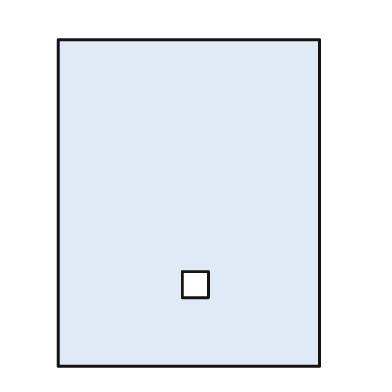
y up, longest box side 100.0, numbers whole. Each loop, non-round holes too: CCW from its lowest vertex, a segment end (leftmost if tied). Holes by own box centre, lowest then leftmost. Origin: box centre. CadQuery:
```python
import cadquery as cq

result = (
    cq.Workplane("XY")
    .moveTo(-40.0, -50.0)
    .lineTo(40.0, -50.0)
    .lineTo(40.0, 50.0)
    .lineTo(-40.0, 50.0)
    .close()
    .moveTo(-2.0, -29.0)
    .lineTo(6.0, -29.0)
    .lineTo(6.0, -21.0)
    .lineTo(-2.0, -21.0)
    .close()
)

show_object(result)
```